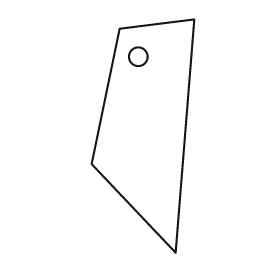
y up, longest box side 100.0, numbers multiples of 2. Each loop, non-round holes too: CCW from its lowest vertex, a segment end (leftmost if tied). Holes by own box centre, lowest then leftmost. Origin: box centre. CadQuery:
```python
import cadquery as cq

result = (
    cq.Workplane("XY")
    .moveTo(14.0, -50.0)
    .lineTo(22.0, 50.0)
    .lineTo(-10.0, 46.0)
    .lineTo(-22.0, -12.0)
    .close()
    .moveTo(-2.0, 34.0)
    .circle(4.0)
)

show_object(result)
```